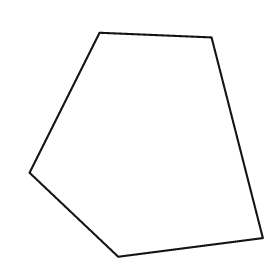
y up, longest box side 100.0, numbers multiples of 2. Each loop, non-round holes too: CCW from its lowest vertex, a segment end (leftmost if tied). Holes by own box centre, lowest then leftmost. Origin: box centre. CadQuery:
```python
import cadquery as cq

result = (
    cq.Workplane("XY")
    .moveTo(-12.0, -48.0)
    .lineTo(50.0, -40.0)
    .lineTo(28.0, 46.0)
    .lineTo(-20.0, 48.0)
    .lineTo(-50.0, -12.0)
    .close()
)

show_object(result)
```